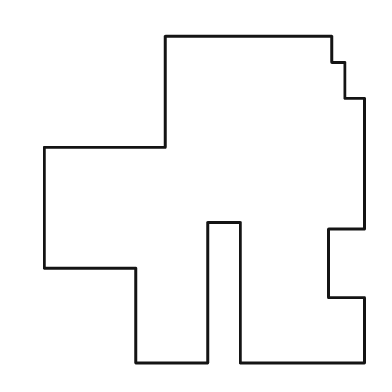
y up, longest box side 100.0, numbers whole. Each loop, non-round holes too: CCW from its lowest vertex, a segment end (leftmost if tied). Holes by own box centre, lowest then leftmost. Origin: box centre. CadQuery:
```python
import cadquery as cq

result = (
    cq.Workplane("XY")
    .moveTo(-21.0, -50.0)
    .lineTo(1.0, -50.0)
    .lineTo(1.0, -7.0)
    .lineTo(11.0, -7.0)
    .lineTo(11.0, -50.0)
    .lineTo(49.0, -50.0)
    .lineTo(49.0, -30.0)
    .lineTo(38.0, -30.0)
    .lineTo(38.0, -9.0)
    .lineTo(49.0, -9.0)
    .lineTo(49.0, 31.0)
    .lineTo(43.0, 31.0)
    .lineTo(43.0, 42.0)
    .lineTo(39.0, 42.0)
    .lineTo(39.0, 50.0)
    .lineTo(-12.0, 50.0)
    .lineTo(-12.0, 16.0)
    .lineTo(-49.0, 16.0)
    .lineTo(-49.0, -21.0)
    .lineTo(-21.0, -21.0)
    .close()
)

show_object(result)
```